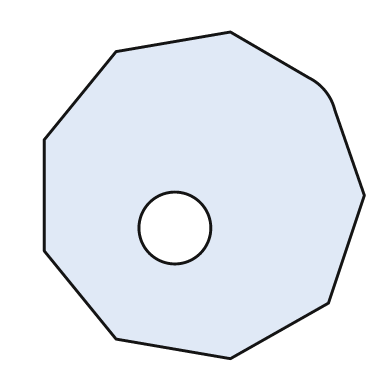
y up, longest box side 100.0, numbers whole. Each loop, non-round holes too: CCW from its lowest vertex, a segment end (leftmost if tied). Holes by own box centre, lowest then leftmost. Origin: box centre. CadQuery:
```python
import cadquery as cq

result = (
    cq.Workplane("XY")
    .moveTo(8.0, -50.0)
    .lineTo(38.0, -33.0)
    .lineTo(49.0, 0.0)
    .lineTo(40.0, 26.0)
    .threePointArc((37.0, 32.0), (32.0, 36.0))
    .lineTo(8.0, 50.0)
    .lineTo(-27.0, 44.0)
    .lineTo(-49.0, 17.0)
    .lineTo(-49.0, -17.0)
    .lineTo(-27.0, -44.0)
    .close()
    .moveTo(-9.0, -10.0)
    .circle(11.0)
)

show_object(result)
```